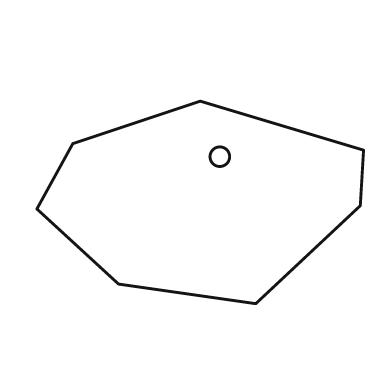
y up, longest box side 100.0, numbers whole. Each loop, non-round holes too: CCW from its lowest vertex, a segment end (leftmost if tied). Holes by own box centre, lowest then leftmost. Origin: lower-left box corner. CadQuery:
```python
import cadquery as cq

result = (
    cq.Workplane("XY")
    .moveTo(67.0, 0.0)
    .lineTo(99.0, 30.0)
    .lineTo(100.0, 47.0)
    .lineTo(50.0, 62.0)
    .lineTo(11.0, 49.0)
    .lineTo(0.0, 29.0)
    .lineTo(25.0, 6.0)
    .close()
    .moveTo(56.0, 45.0)
    .circle(3.0)
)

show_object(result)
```